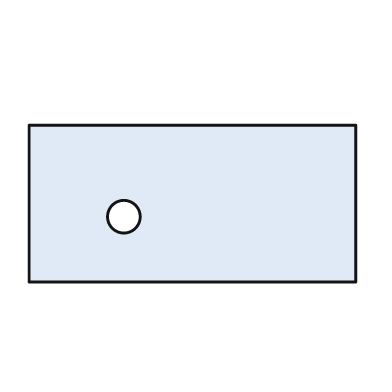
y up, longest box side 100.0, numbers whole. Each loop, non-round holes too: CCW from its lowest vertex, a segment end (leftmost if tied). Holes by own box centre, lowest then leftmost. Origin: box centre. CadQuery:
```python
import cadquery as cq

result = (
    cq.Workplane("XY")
    .moveTo(-50.0, -24.0)
    .lineTo(50.0, -24.0)
    .lineTo(50.0, 24.0)
    .lineTo(-50.0, 24.0)
    .close()
    .moveTo(-21.0, -4.0)
    .circle(5.0)
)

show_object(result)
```